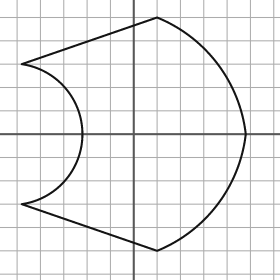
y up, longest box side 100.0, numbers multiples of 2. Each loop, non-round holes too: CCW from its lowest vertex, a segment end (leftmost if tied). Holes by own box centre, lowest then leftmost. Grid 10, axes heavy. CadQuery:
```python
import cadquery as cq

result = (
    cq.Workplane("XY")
    .moveTo(10.0, -50.0)
    .threePointArc((36.0, -30.0), (48.0, 0.0))
    .threePointArc((36.0, 30.0), (10.0, 50.0))
    .lineTo(-48.0, 30.0)
    .threePointArc((-22.0, 0.0), (-48.0, -30.0))
    .close()
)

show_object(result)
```